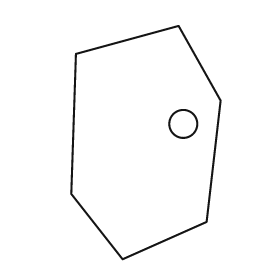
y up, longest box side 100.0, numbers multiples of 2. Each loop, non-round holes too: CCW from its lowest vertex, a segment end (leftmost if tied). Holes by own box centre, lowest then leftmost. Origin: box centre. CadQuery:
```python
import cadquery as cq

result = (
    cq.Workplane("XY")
    .moveTo(-10.0, -50.0)
    .lineTo(26.0, -34.0)
    .lineTo(32.0, 18.0)
    .lineTo(14.0, 50.0)
    .lineTo(-30.0, 38.0)
    .lineTo(-32.0, -22.0)
    .close()
    .moveTo(16.0, 8.0)
    .circle(6.0)
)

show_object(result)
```